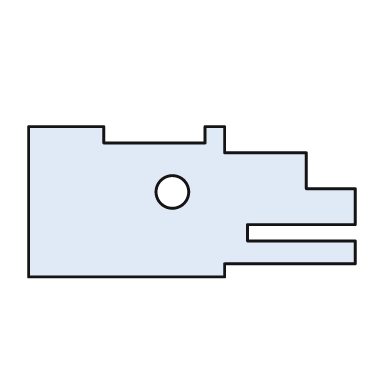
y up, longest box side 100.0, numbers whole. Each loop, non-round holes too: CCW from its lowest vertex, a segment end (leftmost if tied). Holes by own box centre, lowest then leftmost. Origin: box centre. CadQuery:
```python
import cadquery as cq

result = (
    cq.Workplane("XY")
    .moveTo(-50.0, -23.0)
    .lineTo(10.0, -23.0)
    .lineTo(10.0, -19.0)
    .lineTo(50.0, -19.0)
    .lineTo(50.0, -12.0)
    .lineTo(17.0, -12.0)
    .lineTo(17.0, -7.0)
    .lineTo(50.0, -7.0)
    .lineTo(50.0, 4.0)
    .lineTo(35.0, 4.0)
    .lineTo(35.0, 15.0)
    .lineTo(10.0, 15.0)
    .lineTo(10.0, 23.0)
    .lineTo(4.0, 23.0)
    .lineTo(4.0, 18.0)
    .lineTo(-27.0, 18.0)
    .lineTo(-27.0, 23.0)
    .lineTo(-50.0, 23.0)
    .close()
    .moveTo(-6.0, 3.0)
    .circle(5.0)
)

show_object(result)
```